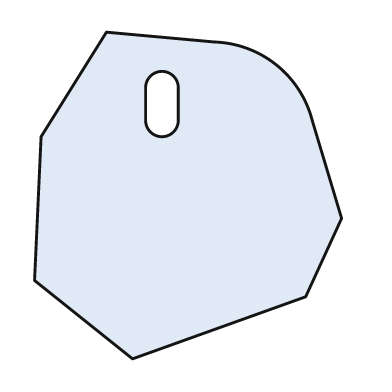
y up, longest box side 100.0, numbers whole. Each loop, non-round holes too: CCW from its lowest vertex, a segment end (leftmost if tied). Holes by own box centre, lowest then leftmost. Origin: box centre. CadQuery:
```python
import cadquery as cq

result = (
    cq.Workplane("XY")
    .moveTo(-17.0, -50.0)
    .lineTo(36.0, -31.0)
    .lineTo(47.0, -7.0)
    .lineTo(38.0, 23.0)
    .threePointArc((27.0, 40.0), (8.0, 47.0))
    .lineTo(-25.0, 50.0)
    .lineTo(-45.0, 18.0)
    .lineTo(-47.0, -26.0)
    .close()
    .moveTo(-13.0, 23.0)
    .threePointArc((-8.0, 18.0), (-3.0, 23.0))
    .lineTo(-3.0, 33.0)
    .threePointArc((-8.0, 38.0), (-13.0, 33.0))
    .close()
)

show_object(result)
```